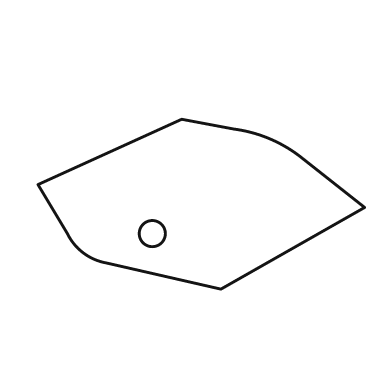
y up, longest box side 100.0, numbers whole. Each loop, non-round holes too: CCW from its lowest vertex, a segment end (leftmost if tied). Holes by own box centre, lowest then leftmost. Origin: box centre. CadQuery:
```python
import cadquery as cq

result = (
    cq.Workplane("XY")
    .moveTo(6.0, -26.0)
    .lineTo(50.0, -1.0)
    .lineTo(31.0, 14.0)
    .threePointArc((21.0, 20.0), (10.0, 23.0))
    .lineTo(-6.0, 26.0)
    .lineTo(-50.0, 6.0)
    .lineTo(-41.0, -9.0)
    .threePointArc((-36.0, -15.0), (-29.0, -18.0))
    .close()
    .moveTo(-15.0, -9.0)
    .circle(4.0)
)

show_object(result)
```